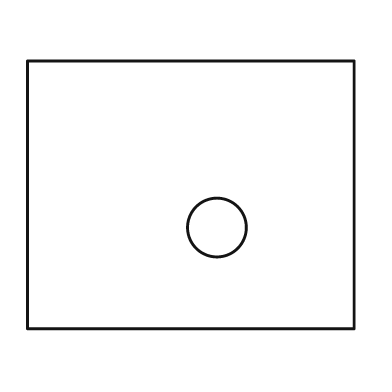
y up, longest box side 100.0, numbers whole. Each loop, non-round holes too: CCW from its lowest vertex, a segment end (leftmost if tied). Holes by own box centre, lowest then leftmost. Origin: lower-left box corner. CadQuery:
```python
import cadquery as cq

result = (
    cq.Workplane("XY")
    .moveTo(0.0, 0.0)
    .lineTo(100.0, 0.0)
    .lineTo(100.0, 82.0)
    .lineTo(0.0, 82.0)
    .close()
    .moveTo(58.0, 31.0)
    .circle(9.0)
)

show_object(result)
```